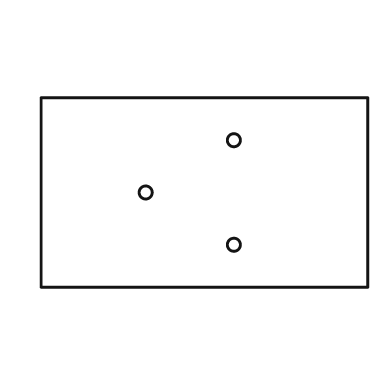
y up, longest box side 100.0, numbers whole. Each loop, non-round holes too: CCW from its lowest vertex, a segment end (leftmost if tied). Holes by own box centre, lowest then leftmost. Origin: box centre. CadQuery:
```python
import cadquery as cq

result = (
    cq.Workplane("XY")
    .moveTo(-50.0, -29.0)
    .lineTo(50.0, -29.0)
    .lineTo(50.0, 29.0)
    .lineTo(-50.0, 29.0)
    .close()
    .moveTo(9.0, -16.0)
    .circle(2.0)
    .moveTo(-18.0, 0.0)
    .circle(2.0)
    .moveTo(9.0, 16.0)
    .circle(2.0)
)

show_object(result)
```